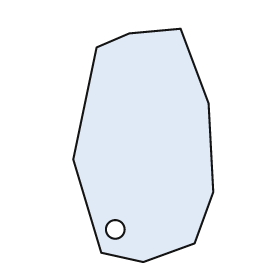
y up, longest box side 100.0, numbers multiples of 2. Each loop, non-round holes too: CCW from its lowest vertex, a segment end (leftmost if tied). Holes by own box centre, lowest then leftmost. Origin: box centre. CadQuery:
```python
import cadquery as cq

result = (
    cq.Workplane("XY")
    .moveTo(0.0, -50.0)
    .lineTo(22.0, -42.0)
    .lineTo(30.0, -20.0)
    .lineTo(28.0, 18.0)
    .lineTo(16.0, 50.0)
    .lineTo(-6.0, 48.0)
    .lineTo(-20.0, 42.0)
    .lineTo(-30.0, -6.0)
    .lineTo(-18.0, -46.0)
    .close()
    .moveTo(-12.0, -36.0)
    .circle(4.0)
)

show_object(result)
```